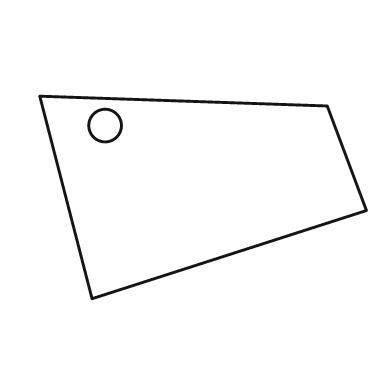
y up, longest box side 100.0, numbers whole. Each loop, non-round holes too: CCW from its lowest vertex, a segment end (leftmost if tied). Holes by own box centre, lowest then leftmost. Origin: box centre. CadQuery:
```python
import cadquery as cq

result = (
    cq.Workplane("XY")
    .moveTo(-34.0, -31.0)
    .lineTo(50.0, -4.0)
    .lineTo(38.0, 28.0)
    .lineTo(-50.0, 31.0)
    .close()
    .moveTo(-30.0, 22.0)
    .circle(5.0)
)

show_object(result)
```